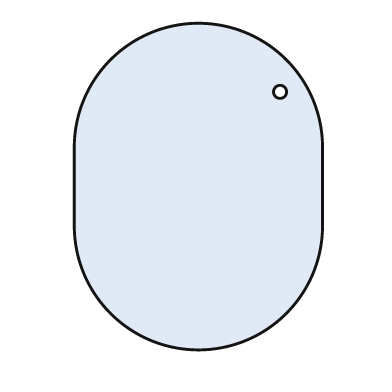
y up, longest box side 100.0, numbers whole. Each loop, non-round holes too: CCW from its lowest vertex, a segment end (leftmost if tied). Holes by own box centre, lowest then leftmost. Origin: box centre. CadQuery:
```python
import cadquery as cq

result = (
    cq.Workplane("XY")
    .moveTo(-38.0, -12.0)
    .threePointArc((0.0, -50.0), (38.0, -12.0))
    .lineTo(38.0, 12.0)
    .threePointArc((0.0, 50.0), (-38.0, 12.0))
    .close()
    .moveTo(25.0, 29.0)
    .circle(2.0)
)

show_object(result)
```